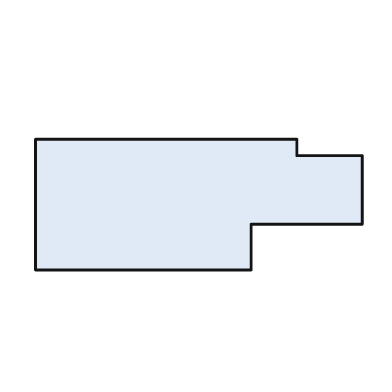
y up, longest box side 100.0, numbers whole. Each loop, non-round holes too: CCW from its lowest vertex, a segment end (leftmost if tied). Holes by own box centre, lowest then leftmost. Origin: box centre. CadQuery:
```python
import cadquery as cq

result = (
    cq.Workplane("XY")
    .moveTo(-50.0, -20.0)
    .lineTo(16.0, -20.0)
    .lineTo(16.0, -6.0)
    .lineTo(50.0, -6.0)
    .lineTo(50.0, 15.0)
    .lineTo(30.0, 15.0)
    .lineTo(30.0, 20.0)
    .lineTo(-50.0, 20.0)
    .close()
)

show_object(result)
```